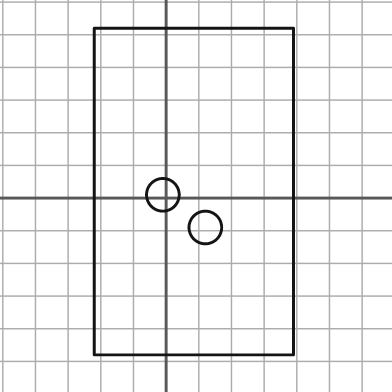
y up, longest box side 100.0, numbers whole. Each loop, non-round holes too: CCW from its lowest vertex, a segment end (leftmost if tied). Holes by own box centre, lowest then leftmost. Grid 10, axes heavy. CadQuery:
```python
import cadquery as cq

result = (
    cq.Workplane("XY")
    .moveTo(-22.0, -48.0)
    .lineTo(39.0, -48.0)
    .lineTo(39.0, 52.0)
    .lineTo(-22.0, 52.0)
    .close()
    .moveTo(12.0, -9.0)
    .circle(5.0)
    .moveTo(-1.0, 1.0)
    .circle(5.0)
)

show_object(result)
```